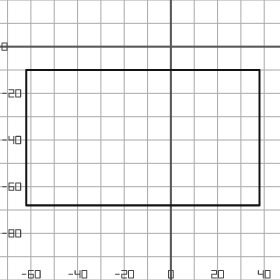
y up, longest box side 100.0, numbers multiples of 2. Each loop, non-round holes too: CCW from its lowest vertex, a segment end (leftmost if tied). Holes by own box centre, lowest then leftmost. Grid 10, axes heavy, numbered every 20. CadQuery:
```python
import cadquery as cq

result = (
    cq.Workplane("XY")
    .moveTo(-62.0, -68.0)
    .lineTo(38.0, -68.0)
    .lineTo(38.0, -10.0)
    .lineTo(-62.0, -10.0)
    .close()
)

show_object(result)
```